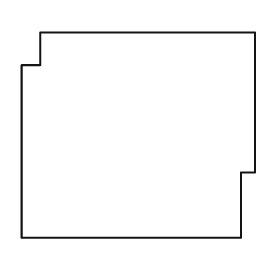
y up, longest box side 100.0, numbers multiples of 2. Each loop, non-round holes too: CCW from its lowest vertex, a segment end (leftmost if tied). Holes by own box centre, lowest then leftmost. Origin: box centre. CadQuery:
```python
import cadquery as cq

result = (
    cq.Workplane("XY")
    .moveTo(-50.0, -44.0)
    .lineTo(44.0, -44.0)
    .lineTo(44.0, -16.0)
    .lineTo(50.0, -16.0)
    .lineTo(50.0, 44.0)
    .lineTo(-42.0, 44.0)
    .lineTo(-42.0, 30.0)
    .lineTo(-50.0, 30.0)
    .close()
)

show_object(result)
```